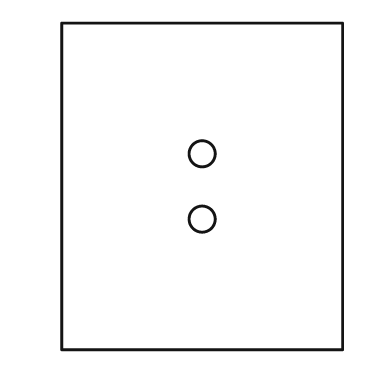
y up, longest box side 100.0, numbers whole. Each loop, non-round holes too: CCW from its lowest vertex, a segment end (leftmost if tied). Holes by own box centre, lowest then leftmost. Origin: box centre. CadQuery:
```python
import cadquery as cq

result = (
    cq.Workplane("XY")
    .moveTo(-43.0, -50.0)
    .lineTo(43.0, -50.0)
    .lineTo(43.0, 50.0)
    .lineTo(-43.0, 50.0)
    .close()
    .moveTo(0.0, -10.0)
    .circle(4.0)
    .moveTo(0.0, 10.0)
    .circle(4.0)
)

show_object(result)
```